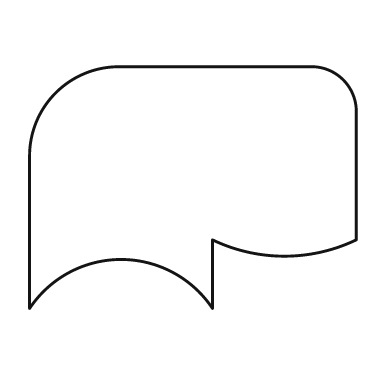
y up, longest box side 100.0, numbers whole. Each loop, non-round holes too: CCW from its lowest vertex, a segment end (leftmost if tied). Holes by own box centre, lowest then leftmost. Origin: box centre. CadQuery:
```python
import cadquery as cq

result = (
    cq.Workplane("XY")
    .moveTo(-50.0, -37.0)
    .threePointArc((-22.0, -22.0), (6.0, -37.0))
    .lineTo(6.0, -16.0)
    .threePointArc((28.0, -21.0), (50.0, -16.0))
    .lineTo(50.0, 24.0)
    .threePointArc((46.0, 33.0), (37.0, 37.0))
    .lineTo(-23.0, 37.0)
    .threePointArc((-42.0, 29.0), (-50.0, 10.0))
    .close()
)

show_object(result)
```